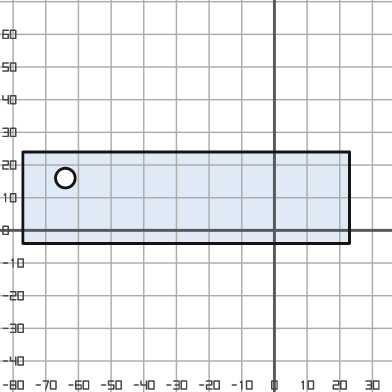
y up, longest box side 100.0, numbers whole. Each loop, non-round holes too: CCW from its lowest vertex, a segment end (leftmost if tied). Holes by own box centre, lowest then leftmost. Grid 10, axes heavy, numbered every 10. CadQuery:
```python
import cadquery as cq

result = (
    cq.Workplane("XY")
    .moveTo(-77.0, -4.0)
    .lineTo(23.0, -4.0)
    .lineTo(23.0, 24.0)
    .lineTo(-77.0, 24.0)
    .close()
    .moveTo(-64.0, 16.0)
    .circle(3.0)
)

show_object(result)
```